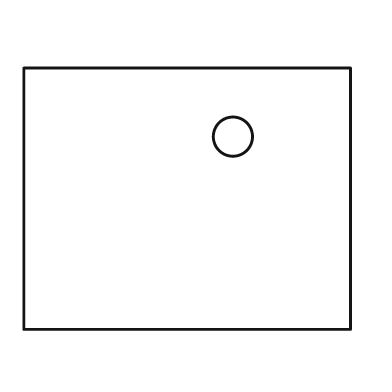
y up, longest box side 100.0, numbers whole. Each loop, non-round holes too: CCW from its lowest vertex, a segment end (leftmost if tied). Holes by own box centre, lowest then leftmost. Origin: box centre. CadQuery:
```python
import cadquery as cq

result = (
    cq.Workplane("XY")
    .moveTo(-50.0, -40.0)
    .lineTo(50.0, -40.0)
    .lineTo(50.0, 40.0)
    .lineTo(-50.0, 40.0)
    .close()
    .moveTo(14.0, 19.0)
    .circle(6.0)
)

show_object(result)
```